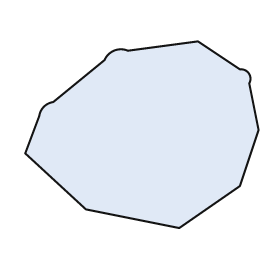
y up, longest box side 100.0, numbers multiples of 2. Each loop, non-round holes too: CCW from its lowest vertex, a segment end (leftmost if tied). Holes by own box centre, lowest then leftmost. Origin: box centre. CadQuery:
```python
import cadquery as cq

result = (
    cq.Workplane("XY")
    .moveTo(16.0, -40.0)
    .lineTo(42.0, -22.0)
    .lineTo(50.0, 2.0)
    .lineTo(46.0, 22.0)
    .threePointArc((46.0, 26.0), (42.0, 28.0))
    .lineTo(24.0, 40.0)
    .lineTo(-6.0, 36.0)
    .threePointArc((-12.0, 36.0), (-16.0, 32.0))
    .lineTo(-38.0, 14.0)
    .threePointArc((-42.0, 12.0), (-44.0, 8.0))
    .lineTo(-50.0, -8.0)
    .lineTo(-24.0, -32.0)
    .close()
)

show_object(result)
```